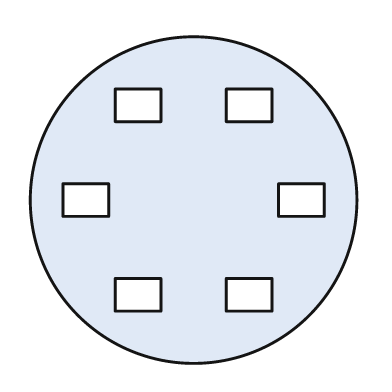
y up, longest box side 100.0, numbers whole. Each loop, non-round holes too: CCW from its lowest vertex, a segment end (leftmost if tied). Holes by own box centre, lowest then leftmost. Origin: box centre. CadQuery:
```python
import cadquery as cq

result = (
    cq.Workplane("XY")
    .moveTo(0.0, 0.0)
    .circle(50.0)
    .moveTo(-24.0, -34.0)
    .lineTo(-10.0, -34.0)
    .lineTo(-10.0, -24.0)
    .lineTo(-24.0, -24.0)
    .close()
    .moveTo(10.0, -34.0)
    .lineTo(24.0, -34.0)
    .lineTo(24.0, -24.0)
    .lineTo(10.0, -24.0)
    .close()
    .moveTo(-40.0, -5.0)
    .lineTo(-26.0, -5.0)
    .lineTo(-26.0, 5.0)
    .lineTo(-40.0, 5.0)
    .close()
    .moveTo(26.0, -5.0)
    .lineTo(40.0, -5.0)
    .lineTo(40.0, 5.0)
    .lineTo(26.0, 5.0)
    .close()
    .moveTo(-24.0, 24.0)
    .lineTo(-10.0, 24.0)
    .lineTo(-10.0, 34.0)
    .lineTo(-24.0, 34.0)
    .close()
    .moveTo(10.0, 24.0)
    .lineTo(24.0, 24.0)
    .lineTo(24.0, 34.0)
    .lineTo(10.0, 34.0)
    .close()
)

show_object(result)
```